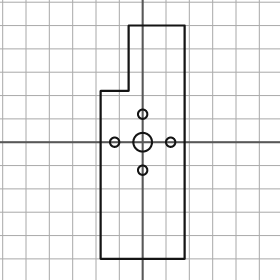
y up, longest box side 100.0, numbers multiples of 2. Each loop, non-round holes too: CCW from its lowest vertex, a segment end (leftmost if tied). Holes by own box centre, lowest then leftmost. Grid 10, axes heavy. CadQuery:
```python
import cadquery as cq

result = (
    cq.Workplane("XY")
    .moveTo(-18.0, -50.0)
    .lineTo(18.0, -50.0)
    .lineTo(18.0, 50.0)
    .lineTo(-6.0, 50.0)
    .lineTo(-6.0, 22.0)
    .lineTo(-18.0, 22.0)
    .close()
    .moveTo(0.0, -12.0)
    .circle(2.0)
    .moveTo(-12.0, 0.0)
    .circle(2.0)
    .moveTo(0.0, 0.0)
    .circle(4.0)
    .moveTo(12.0, 0.0)
    .circle(2.0)
    .moveTo(0.0, 12.0)
    .circle(2.0)
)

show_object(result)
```